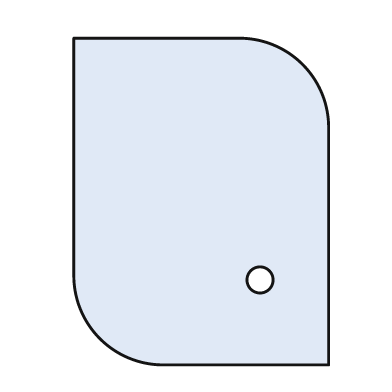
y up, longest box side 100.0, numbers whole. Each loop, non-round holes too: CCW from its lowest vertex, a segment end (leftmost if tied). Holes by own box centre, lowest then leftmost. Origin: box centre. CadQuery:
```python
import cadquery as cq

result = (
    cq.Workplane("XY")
    .moveTo(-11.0, -50.0)
    .lineTo(39.0, -50.0)
    .lineTo(39.0, 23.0)
    .threePointArc((31.0, 42.0), (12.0, 50.0))
    .lineTo(-39.0, 50.0)
    .lineTo(-39.0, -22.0)
    .threePointArc((-31.0, -42.0), (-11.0, -50.0))
    .close()
    .moveTo(18.0, -24.0)
    .circle(4.0)
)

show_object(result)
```